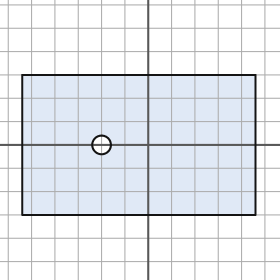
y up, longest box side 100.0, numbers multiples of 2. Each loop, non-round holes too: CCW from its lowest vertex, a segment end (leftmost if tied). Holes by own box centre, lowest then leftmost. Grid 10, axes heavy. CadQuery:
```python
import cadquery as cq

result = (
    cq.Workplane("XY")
    .moveTo(-54.0, -30.0)
    .lineTo(46.0, -30.0)
    .lineTo(46.0, 30.0)
    .lineTo(-54.0, 30.0)
    .close()
    .moveTo(-20.0, 0.0)
    .circle(4.0)
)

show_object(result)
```